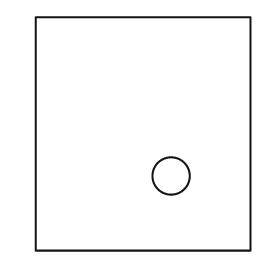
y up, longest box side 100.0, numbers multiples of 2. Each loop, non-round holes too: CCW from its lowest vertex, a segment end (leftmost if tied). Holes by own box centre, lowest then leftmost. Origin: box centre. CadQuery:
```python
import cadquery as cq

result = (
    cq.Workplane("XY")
    .moveTo(-46.0, -50.0)
    .lineTo(46.0, -50.0)
    .lineTo(46.0, 50.0)
    .lineTo(-46.0, 50.0)
    .close()
    .moveTo(12.0, -18.0)
    .circle(8.0)
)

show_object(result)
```